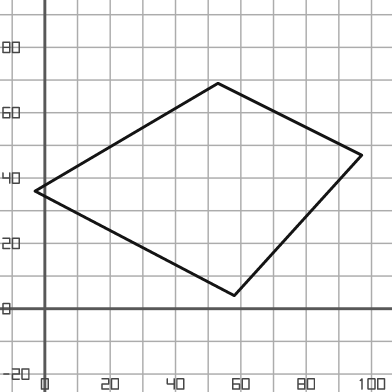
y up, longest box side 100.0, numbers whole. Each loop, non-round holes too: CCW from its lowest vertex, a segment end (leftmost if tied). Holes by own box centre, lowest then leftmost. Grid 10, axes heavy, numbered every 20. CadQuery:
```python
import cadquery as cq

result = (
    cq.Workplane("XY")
    .moveTo(58.0, 4.0)
    .lineTo(97.0, 47.0)
    .lineTo(53.0, 69.0)
    .lineTo(-3.0, 36.0)
    .close()
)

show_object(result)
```